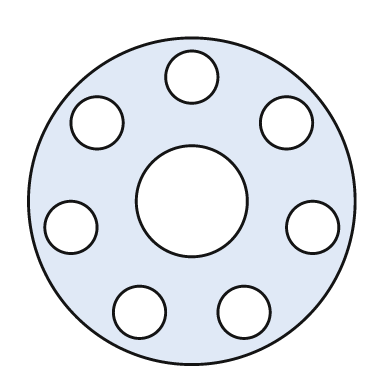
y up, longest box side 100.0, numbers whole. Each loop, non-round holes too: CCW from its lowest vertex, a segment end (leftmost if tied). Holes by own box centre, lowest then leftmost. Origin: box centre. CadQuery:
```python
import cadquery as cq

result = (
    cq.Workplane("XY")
    .moveTo(0.0, 0.0)
    .circle(50.0)
    .moveTo(-16.0, -34.0)
    .circle(8.0)
    .moveTo(16.0, -34.0)
    .circle(8.0)
    .moveTo(-37.0, -8.0)
    .circle(8.0)
    .moveTo(37.0, -8.0)
    .circle(8.0)
    .moveTo(0.0, 0.0)
    .circle(17.0)
    .moveTo(-29.0, 24.0)
    .circle(8.0)
    .moveTo(29.0, 24.0)
    .circle(8.0)
    .moveTo(0.0, 38.0)
    .circle(8.0)
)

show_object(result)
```